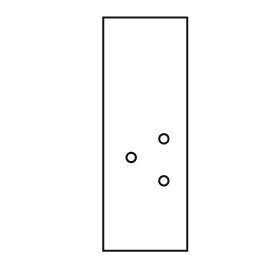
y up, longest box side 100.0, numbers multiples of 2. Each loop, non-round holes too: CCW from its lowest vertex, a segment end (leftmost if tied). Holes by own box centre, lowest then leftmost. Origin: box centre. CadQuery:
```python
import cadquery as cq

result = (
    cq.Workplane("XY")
    .moveTo(-18.0, -50.0)
    .lineTo(18.0, -50.0)
    .lineTo(18.0, 50.0)
    .lineTo(-18.0, 50.0)
    .close()
    .moveTo(8.0, -20.0)
    .circle(2.0)
    .moveTo(-6.0, -10.0)
    .circle(2.0)
    .moveTo(8.0, -2.0)
    .circle(2.0)
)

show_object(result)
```